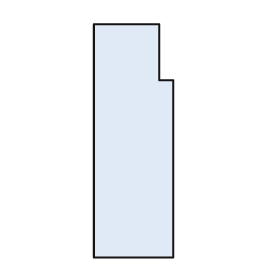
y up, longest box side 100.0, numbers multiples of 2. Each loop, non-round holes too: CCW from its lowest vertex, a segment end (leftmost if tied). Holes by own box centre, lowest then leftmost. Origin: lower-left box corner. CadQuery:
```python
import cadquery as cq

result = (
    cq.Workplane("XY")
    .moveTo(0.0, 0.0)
    .lineTo(34.0, 0.0)
    .lineTo(34.0, 76.0)
    .lineTo(28.0, 76.0)
    .lineTo(28.0, 100.0)
    .lineTo(0.0, 100.0)
    .close()
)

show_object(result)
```